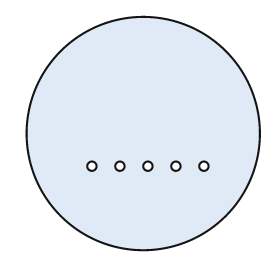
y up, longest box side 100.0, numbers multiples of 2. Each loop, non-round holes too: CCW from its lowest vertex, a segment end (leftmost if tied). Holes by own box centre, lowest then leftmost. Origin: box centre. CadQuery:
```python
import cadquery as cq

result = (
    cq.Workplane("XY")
    .moveTo(0.0, 0.0)
    .circle(50.0)
    .moveTo(-22.0, -14.0)
    .circle(2.0)
    .moveTo(-10.0, -14.0)
    .circle(2.0)
    .moveTo(2.0, -14.0)
    .circle(2.0)
    .moveTo(14.0, -14.0)
    .circle(2.0)
    .moveTo(26.0, -14.0)
    .circle(2.0)
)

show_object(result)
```